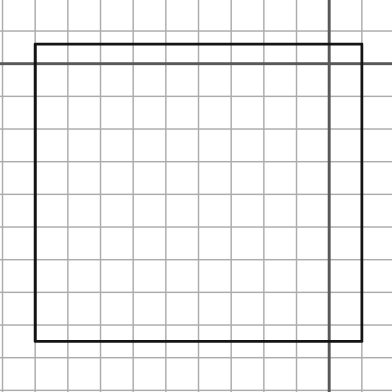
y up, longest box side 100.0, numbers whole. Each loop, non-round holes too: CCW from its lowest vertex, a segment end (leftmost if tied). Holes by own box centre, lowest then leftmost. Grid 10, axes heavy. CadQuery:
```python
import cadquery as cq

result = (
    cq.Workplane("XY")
    .moveTo(-90.0, -85.0)
    .lineTo(10.0, -85.0)
    .lineTo(10.0, 6.0)
    .lineTo(-90.0, 6.0)
    .close()
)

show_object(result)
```